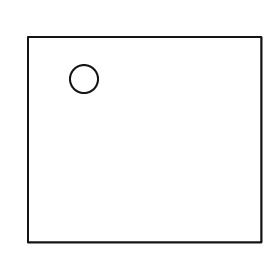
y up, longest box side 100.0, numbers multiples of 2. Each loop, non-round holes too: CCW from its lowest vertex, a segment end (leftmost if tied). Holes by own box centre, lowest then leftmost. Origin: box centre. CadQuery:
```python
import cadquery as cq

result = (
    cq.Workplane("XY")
    .moveTo(-50.0, -44.0)
    .lineTo(50.0, -44.0)
    .lineTo(50.0, 44.0)
    .lineTo(-50.0, 44.0)
    .close()
    .moveTo(-26.0, 26.0)
    .circle(6.0)
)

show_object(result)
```